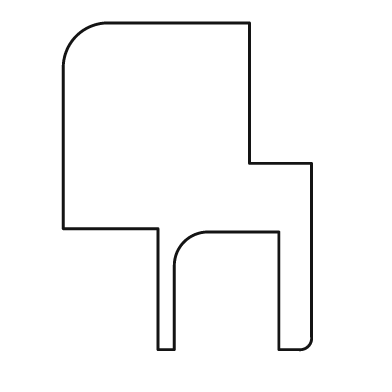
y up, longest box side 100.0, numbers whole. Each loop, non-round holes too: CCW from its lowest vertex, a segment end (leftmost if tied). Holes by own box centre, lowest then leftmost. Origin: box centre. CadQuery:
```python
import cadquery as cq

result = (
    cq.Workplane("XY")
    .moveTo(-9.0, -50.0)
    .lineTo(-4.0, -50.0)
    .lineTo(-4.0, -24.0)
    .threePointArc((-1.0, -17.0), (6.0, -14.0))
    .lineTo(28.0, -14.0)
    .lineTo(28.0, -50.0)
    .lineTo(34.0, -50.0)
    .threePointArc((37.0, -49.0), (38.0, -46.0))
    .lineTo(38.0, 7.0)
    .lineTo(19.0, 7.0)
    .lineTo(19.0, 50.0)
    .lineTo(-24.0, 50.0)
    .threePointArc((-34.0, 46.0), (-38.0, 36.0))
    .lineTo(-38.0, -13.0)
    .lineTo(-9.0, -13.0)
    .close()
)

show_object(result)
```